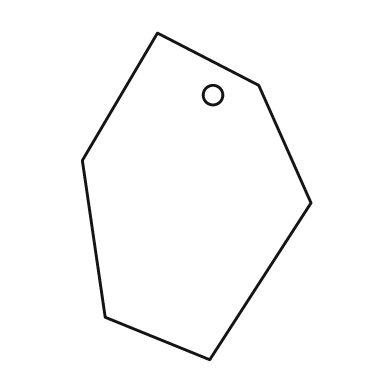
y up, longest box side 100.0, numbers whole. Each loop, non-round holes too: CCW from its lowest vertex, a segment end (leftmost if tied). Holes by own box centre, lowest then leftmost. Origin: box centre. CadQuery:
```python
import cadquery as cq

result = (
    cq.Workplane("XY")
    .moveTo(4.0, -50.0)
    .lineTo(35.0, -2.0)
    .lineTo(19.0, 34.0)
    .lineTo(-12.0, 50.0)
    .lineTo(-35.0, 11.0)
    .lineTo(-28.0, -37.0)
    .close()
    .moveTo(5.0, 31.0)
    .circle(3.0)
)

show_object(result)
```